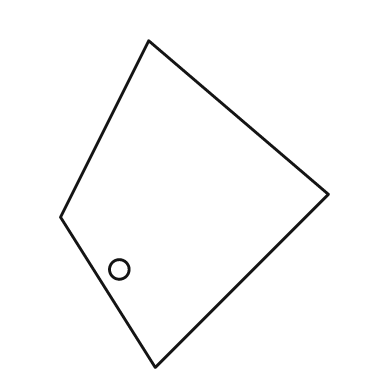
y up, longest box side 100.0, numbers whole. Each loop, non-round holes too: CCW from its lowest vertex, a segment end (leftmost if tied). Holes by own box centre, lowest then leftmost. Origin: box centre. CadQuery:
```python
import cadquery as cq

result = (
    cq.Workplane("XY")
    .moveTo(-12.0, -50.0)
    .lineTo(41.0, 3.0)
    .lineTo(-14.0, 50.0)
    .lineTo(-41.0, -4.0)
    .close()
    .moveTo(-23.0, -20.0)
    .circle(3.0)
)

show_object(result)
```